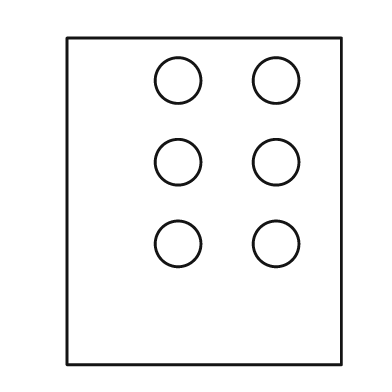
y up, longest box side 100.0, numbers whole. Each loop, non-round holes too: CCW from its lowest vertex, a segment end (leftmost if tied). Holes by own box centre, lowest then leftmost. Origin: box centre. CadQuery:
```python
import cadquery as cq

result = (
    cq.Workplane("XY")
    .moveTo(-42.0, -50.0)
    .lineTo(42.0, -50.0)
    .lineTo(42.0, 50.0)
    .lineTo(-42.0, 50.0)
    .close()
    .moveTo(-8.0, -13.0)
    .circle(7.0)
    .moveTo(22.0, -13.0)
    .circle(7.0)
    .moveTo(-8.0, 12.0)
    .circle(7.0)
    .moveTo(22.0, 12.0)
    .circle(7.0)
    .moveTo(-8.0, 37.0)
    .circle(7.0)
    .moveTo(22.0, 37.0)
    .circle(7.0)
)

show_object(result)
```